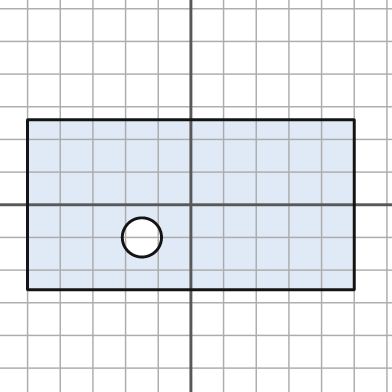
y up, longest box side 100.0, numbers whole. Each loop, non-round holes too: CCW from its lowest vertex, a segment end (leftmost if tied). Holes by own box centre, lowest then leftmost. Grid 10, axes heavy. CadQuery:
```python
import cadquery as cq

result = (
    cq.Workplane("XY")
    .moveTo(-50.0, -26.0)
    .lineTo(50.0, -26.0)
    .lineTo(50.0, 26.0)
    .lineTo(-50.0, 26.0)
    .close()
    .moveTo(-15.0, -10.0)
    .circle(6.0)
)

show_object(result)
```